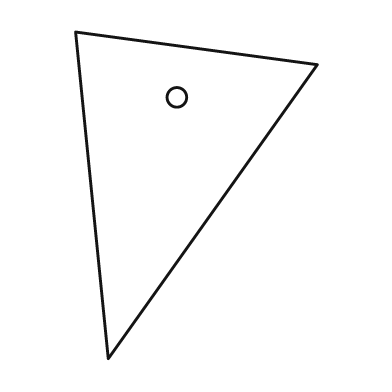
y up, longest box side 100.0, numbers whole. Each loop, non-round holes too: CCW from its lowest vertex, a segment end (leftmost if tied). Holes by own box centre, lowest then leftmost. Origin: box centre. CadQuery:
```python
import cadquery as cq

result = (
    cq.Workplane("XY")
    .moveTo(-27.0, -50.0)
    .lineTo(37.0, 40.0)
    .lineTo(-37.0, 50.0)
    .close()
    .moveTo(-6.0, 30.0)
    .circle(3.0)
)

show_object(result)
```